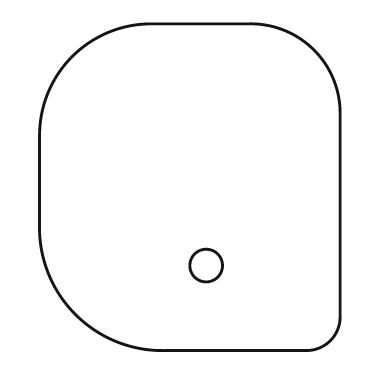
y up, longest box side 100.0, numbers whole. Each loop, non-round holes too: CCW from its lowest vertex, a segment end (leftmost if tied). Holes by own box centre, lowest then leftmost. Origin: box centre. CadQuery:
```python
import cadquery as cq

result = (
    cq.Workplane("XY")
    .moveTo(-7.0, -50.0)
    .lineTo(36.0, -50.0)
    .threePointArc((43.0, -47.0), (46.0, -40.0))
    .lineTo(46.0, 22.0)
    .threePointArc((38.0, 42.0), (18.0, 50.0))
    .lineTo(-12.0, 50.0)
    .threePointArc((-36.0, 40.0), (-46.0, 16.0))
    .lineTo(-46.0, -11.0)
    .threePointArc((-35.0, -39.0), (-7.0, -50.0))
    .close()
    .moveTo(5.0, -24.0)
    .circle(5.0)
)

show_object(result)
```